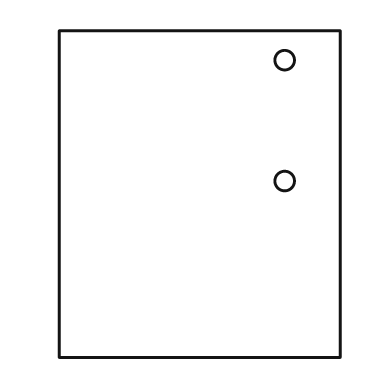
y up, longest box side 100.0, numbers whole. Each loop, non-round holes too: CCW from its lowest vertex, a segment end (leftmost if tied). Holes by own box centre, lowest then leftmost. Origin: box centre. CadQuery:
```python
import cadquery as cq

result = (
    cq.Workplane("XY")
    .moveTo(-43.0, -50.0)
    .lineTo(43.0, -50.0)
    .lineTo(43.0, 50.0)
    .lineTo(-43.0, 50.0)
    .close()
    .moveTo(26.0, 4.0)
    .circle(3.0)
    .moveTo(26.0, 41.0)
    .circle(3.0)
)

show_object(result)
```